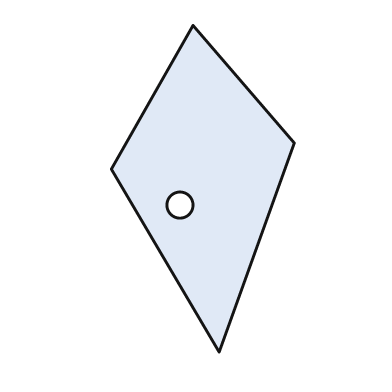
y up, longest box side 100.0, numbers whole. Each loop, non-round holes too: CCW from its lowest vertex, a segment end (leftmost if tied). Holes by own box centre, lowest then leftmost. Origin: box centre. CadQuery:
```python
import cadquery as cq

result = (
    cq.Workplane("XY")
    .moveTo(5.0, -50.0)
    .lineTo(28.0, 14.0)
    .lineTo(-3.0, 50.0)
    .lineTo(-28.0, 6.0)
    .close()
    .moveTo(-7.0, -5.0)
    .circle(4.0)
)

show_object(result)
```